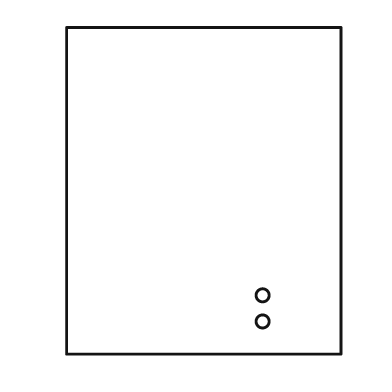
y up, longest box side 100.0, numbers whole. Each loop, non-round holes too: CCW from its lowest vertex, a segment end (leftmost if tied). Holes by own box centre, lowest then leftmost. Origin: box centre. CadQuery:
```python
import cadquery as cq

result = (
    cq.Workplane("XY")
    .moveTo(-42.0, -50.0)
    .lineTo(42.0, -50.0)
    .lineTo(42.0, 50.0)
    .lineTo(-42.0, 50.0)
    .close()
    .moveTo(18.0, -40.0)
    .circle(2.0)
    .moveTo(18.0, -32.0)
    .circle(2.0)
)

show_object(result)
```